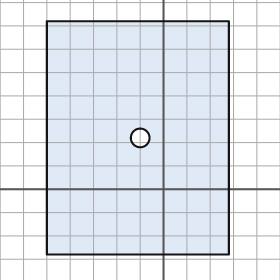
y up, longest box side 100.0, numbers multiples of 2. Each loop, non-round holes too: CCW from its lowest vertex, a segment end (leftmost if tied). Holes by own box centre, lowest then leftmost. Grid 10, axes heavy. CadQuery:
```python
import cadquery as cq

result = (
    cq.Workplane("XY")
    .moveTo(-50.0, -28.0)
    .lineTo(28.0, -28.0)
    .lineTo(28.0, 72.0)
    .lineTo(-50.0, 72.0)
    .close()
    .moveTo(-10.0, 22.0)
    .circle(4.0)
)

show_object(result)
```